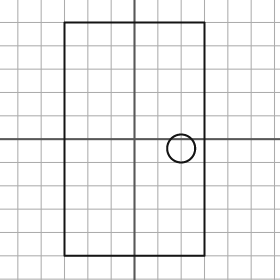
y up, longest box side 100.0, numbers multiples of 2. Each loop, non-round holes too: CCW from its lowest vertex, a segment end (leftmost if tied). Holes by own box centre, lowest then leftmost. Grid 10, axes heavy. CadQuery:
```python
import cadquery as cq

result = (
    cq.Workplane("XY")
    .moveTo(-30.0, -50.0)
    .lineTo(30.0, -50.0)
    .lineTo(30.0, 50.0)
    .lineTo(-30.0, 50.0)
    .close()
    .moveTo(20.0, -4.0)
    .circle(6.0)
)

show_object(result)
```